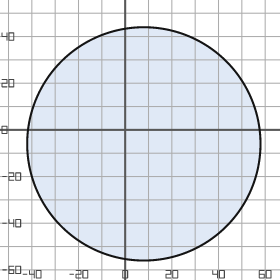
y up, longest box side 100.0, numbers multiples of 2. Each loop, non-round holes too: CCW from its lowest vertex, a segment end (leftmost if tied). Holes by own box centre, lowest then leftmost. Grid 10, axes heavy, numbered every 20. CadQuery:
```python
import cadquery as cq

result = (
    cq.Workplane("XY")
    .moveTo(8.0, -6.0)
    .circle(50.0)
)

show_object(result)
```